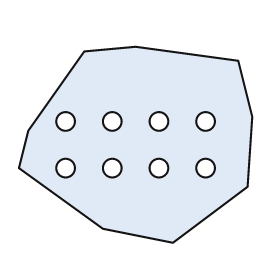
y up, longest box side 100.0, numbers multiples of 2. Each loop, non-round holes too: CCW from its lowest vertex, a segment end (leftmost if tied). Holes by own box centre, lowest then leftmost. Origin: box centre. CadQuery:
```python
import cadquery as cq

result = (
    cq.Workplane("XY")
    .moveTo(16.0, -42.0)
    .lineTo(48.0, -18.0)
    .lineTo(50.0, 12.0)
    .lineTo(44.0, 36.0)
    .lineTo(0.0, 42.0)
    .lineTo(-22.0, 40.0)
    .lineTo(-46.0, 6.0)
    .lineTo(-50.0, -10.0)
    .lineTo(-14.0, -36.0)
    .close()
    .moveTo(-30.0, -10.0)
    .circle(4.0)
    .moveTo(-10.0, -10.0)
    .circle(4.0)
    .moveTo(10.0, -10.0)
    .circle(4.0)
    .moveTo(30.0, -10.0)
    .circle(4.0)
    .moveTo(-30.0, 10.0)
    .circle(4.0)
    .moveTo(-10.0, 10.0)
    .circle(4.0)
    .moveTo(10.0, 10.0)
    .circle(4.0)
    .moveTo(30.0, 10.0)
    .circle(4.0)
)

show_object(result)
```